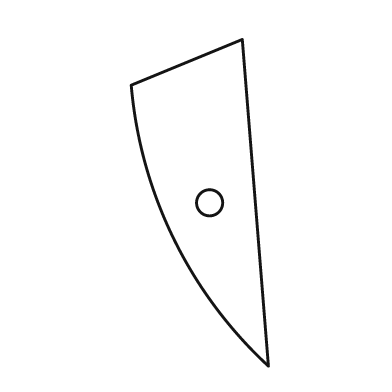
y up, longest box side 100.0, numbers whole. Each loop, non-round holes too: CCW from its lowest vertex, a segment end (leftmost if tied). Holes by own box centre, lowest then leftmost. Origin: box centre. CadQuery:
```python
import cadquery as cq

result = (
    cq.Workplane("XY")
    .moveTo(21.0, -50.0)
    .lineTo(13.0, 50.0)
    .lineTo(-21.0, 36.0)
    .threePointArc((-8.0, -11.0), (21.0, -50.0))
    .close()
    .moveTo(3.0, 0.0)
    .circle(4.0)
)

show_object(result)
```